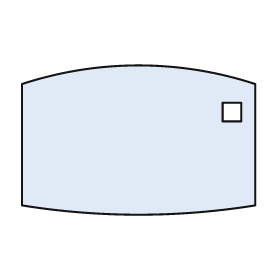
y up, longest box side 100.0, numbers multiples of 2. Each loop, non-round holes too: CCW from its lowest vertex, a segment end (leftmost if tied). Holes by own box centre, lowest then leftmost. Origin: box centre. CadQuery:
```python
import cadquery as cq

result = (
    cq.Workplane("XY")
    .moveTo(-50.0, -28.0)
    .threePointArc((0.0, -32.0), (50.0, -28.0))
    .lineTo(50.0, 24.0)
    .threePointArc((0.0, 32.0), (-50.0, 24.0))
    .close()
    .moveTo(36.0, 8.0)
    .lineTo(44.0, 8.0)
    .lineTo(44.0, 16.0)
    .lineTo(36.0, 16.0)
    .close()
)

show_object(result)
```